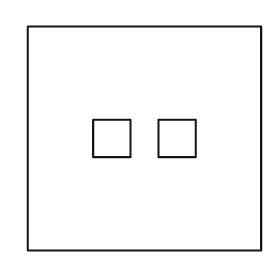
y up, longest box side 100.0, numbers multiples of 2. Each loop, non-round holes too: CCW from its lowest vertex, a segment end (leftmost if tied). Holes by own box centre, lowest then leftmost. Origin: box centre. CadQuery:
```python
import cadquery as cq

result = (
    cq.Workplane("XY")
    .moveTo(-50.0, -48.0)
    .lineTo(50.0, -48.0)
    .lineTo(50.0, 48.0)
    .lineTo(-50.0, 48.0)
    .close()
    .moveTo(-22.0, -8.0)
    .lineTo(-6.0, -8.0)
    .lineTo(-6.0, 8.0)
    .lineTo(-22.0, 8.0)
    .close()
    .moveTo(6.0, -8.0)
    .lineTo(22.0, -8.0)
    .lineTo(22.0, 8.0)
    .lineTo(6.0, 8.0)
    .close()
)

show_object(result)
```